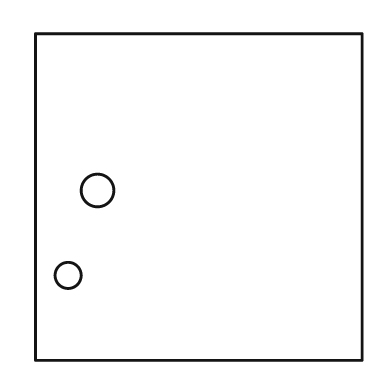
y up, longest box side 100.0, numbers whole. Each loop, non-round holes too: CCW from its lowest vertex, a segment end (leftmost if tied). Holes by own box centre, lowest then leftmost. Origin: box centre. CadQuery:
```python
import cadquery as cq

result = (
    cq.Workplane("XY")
    .moveTo(-50.0, -50.0)
    .lineTo(50.0, -50.0)
    .lineTo(50.0, 50.0)
    .lineTo(-50.0, 50.0)
    .close()
    .moveTo(-40.0, -24.0)
    .circle(4.0)
    .moveTo(-31.0, 2.0)
    .circle(5.0)
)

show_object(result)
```